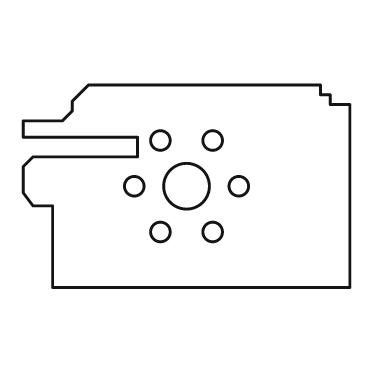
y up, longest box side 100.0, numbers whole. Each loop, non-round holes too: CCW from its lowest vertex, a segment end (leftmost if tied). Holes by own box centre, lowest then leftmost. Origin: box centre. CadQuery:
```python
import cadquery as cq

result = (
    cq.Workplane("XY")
    .moveTo(-41.0, -31.0)
    .lineTo(50.0, -31.0)
    .lineTo(50.0, 25.0)
    .lineTo(44.0, 25.0)
    .lineTo(44.0, 28.0)
    .lineTo(41.0, 28.0)
    .lineTo(41.0, 31.0)
    .lineTo(-30.0, 31.0)
    .lineTo(-35.0, 26.0)
    .lineTo(-35.0, 23.0)
    .lineTo(-38.0, 20.0)
    .lineTo(-50.0, 20.0)
    .lineTo(-50.0, 15.0)
    .lineTo(-15.0, 15.0)
    .lineTo(-15.0, 9.0)
    .lineTo(-47.0, 9.0)
    .lineTo(-50.0, 6.0)
    .lineTo(-50.0, -2.0)
    .lineTo(-47.0, -6.0)
    .lineTo(-41.0, -6.0)
    .close()
    .moveTo(-8.0, -14.0)
    .circle(3.0)
    .moveTo(8.0, -14.0)
    .circle(3.0)
    .moveTo(-16.0, 0.0)
    .circle(3.0)
    .moveTo(0.0, 0.0)
    .circle(7.0)
    .moveTo(16.0, 0.0)
    .circle(3.0)
    .moveTo(-8.0, 14.0)
    .circle(3.0)
    .moveTo(8.0, 14.0)
    .circle(3.0)
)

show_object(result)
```